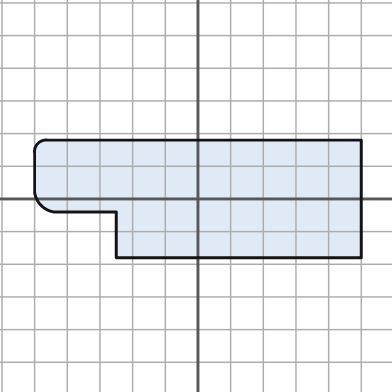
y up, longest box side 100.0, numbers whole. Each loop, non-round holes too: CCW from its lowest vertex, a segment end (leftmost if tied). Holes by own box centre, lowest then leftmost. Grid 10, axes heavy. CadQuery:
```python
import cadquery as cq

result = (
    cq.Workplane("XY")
    .moveTo(-25.0, -18.0)
    .lineTo(50.0, -18.0)
    .lineTo(50.0, 18.0)
    .lineTo(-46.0, 18.0)
    .threePointArc((-49.0, 17.0), (-50.0, 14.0))
    .lineTo(-50.0, 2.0)
    .threePointArc((-48.0, -2.0), (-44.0, -4.0))
    .lineTo(-25.0, -4.0)
    .close()
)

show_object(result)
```